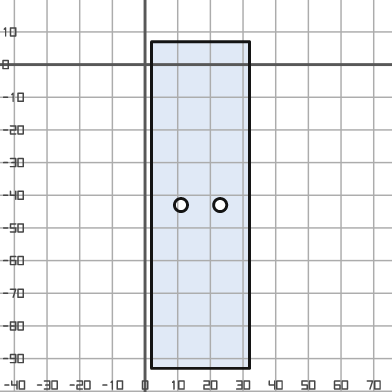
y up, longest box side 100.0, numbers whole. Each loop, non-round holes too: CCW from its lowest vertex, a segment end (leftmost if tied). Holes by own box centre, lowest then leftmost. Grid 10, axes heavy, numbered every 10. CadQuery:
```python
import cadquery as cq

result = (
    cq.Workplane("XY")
    .moveTo(2.0, -93.0)
    .lineTo(32.0, -93.0)
    .lineTo(32.0, 7.0)
    .lineTo(2.0, 7.0)
    .close()
    .moveTo(11.0, -43.0)
    .circle(2.0)
    .moveTo(23.0, -43.0)
    .circle(2.0)
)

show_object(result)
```